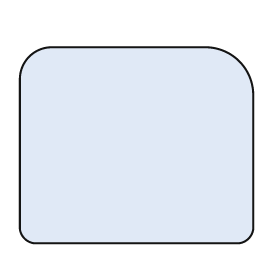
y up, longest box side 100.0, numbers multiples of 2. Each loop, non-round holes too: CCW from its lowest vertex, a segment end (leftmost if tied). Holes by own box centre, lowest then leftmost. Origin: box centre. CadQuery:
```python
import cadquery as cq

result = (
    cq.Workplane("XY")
    .moveTo(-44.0, -42.0)
    .lineTo(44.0, -42.0)
    .threePointArc((48.0, -40.0), (50.0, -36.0))
    .lineTo(50.0, 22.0)
    .threePointArc((44.0, 36.0), (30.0, 42.0))
    .lineTo(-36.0, 42.0)
    .threePointArc((-46.0, 38.0), (-50.0, 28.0))
    .lineTo(-50.0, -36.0)
    .threePointArc((-48.0, -40.0), (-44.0, -42.0))
    .close()
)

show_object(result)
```